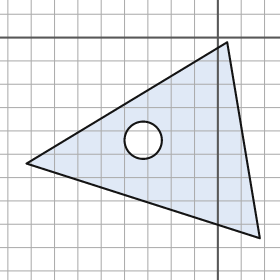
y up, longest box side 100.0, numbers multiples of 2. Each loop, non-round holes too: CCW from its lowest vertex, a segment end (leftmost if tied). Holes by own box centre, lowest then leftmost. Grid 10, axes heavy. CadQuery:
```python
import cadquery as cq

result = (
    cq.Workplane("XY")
    .moveTo(18.0, -86.0)
    .lineTo(4.0, -2.0)
    .lineTo(-82.0, -54.0)
    .close()
    .moveTo(-32.0, -44.0)
    .circle(8.0)
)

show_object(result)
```